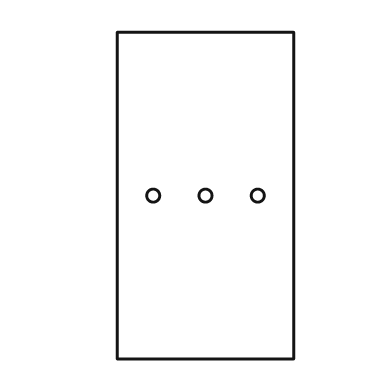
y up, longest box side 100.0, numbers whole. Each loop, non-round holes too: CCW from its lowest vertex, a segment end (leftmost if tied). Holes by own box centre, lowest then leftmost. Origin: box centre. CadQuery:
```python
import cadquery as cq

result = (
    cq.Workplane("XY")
    .moveTo(-27.0, -50.0)
    .lineTo(27.0, -50.0)
    .lineTo(27.0, 50.0)
    .lineTo(-27.0, 50.0)
    .close()
    .moveTo(-16.0, 0.0)
    .circle(2.0)
    .moveTo(0.0, 0.0)
    .circle(2.0)
    .moveTo(16.0, 0.0)
    .circle(2.0)
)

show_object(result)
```